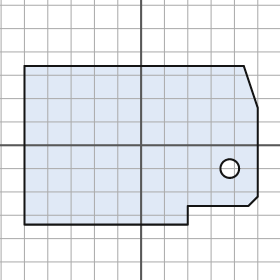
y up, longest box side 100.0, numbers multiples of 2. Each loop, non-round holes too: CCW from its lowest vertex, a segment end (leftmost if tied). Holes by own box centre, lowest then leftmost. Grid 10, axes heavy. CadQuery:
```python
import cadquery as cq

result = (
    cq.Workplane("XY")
    .moveTo(-50.0, -34.0)
    .lineTo(20.0, -34.0)
    .lineTo(20.0, -26.0)
    .lineTo(46.0, -26.0)
    .lineTo(50.0, -22.0)
    .lineTo(50.0, 16.0)
    .lineTo(44.0, 34.0)
    .lineTo(-50.0, 34.0)
    .close()
    .moveTo(38.0, -10.0)
    .circle(4.0)
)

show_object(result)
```